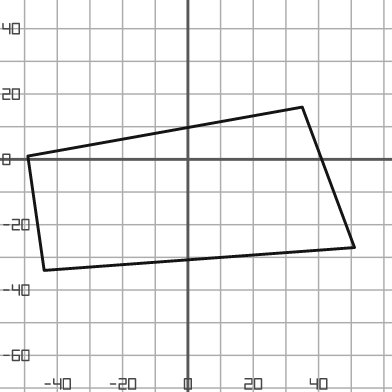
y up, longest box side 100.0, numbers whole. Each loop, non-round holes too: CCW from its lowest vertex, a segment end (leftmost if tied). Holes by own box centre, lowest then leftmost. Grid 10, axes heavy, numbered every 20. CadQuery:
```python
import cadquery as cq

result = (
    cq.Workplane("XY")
    .moveTo(-44.0, -34.0)
    .lineTo(51.0, -27.0)
    .lineTo(35.0, 16.0)
    .lineTo(-49.0, 1.0)
    .close()
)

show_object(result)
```